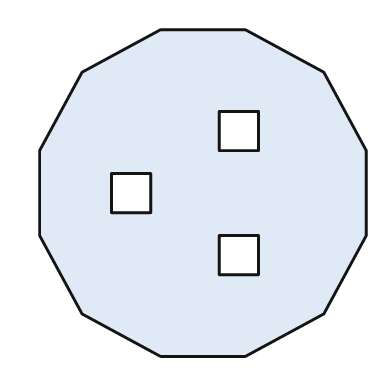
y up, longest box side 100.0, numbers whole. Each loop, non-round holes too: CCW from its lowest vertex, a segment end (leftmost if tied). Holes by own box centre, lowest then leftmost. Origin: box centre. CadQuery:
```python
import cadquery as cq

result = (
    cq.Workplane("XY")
    .moveTo(-13.0, -50.0)
    .lineTo(13.0, -50.0)
    .lineTo(37.0, -37.0)
    .lineTo(50.0, -13.0)
    .lineTo(50.0, 13.0)
    .lineTo(37.0, 37.0)
    .lineTo(13.0, 50.0)
    .lineTo(-13.0, 50.0)
    .lineTo(-37.0, 37.0)
    .lineTo(-50.0, 13.0)
    .lineTo(-50.0, -13.0)
    .lineTo(-37.0, -37.0)
    .close()
    .moveTo(5.0, -25.0)
    .lineTo(17.0, -25.0)
    .lineTo(17.0, -13.0)
    .lineTo(5.0, -13.0)
    .close()
    .moveTo(-28.0, -6.0)
    .lineTo(-16.0, -6.0)
    .lineTo(-16.0, 6.0)
    .lineTo(-28.0, 6.0)
    .close()
    .moveTo(5.0, 13.0)
    .lineTo(17.0, 13.0)
    .lineTo(17.0, 25.0)
    .lineTo(5.0, 25.0)
    .close()
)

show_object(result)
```